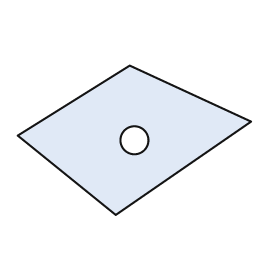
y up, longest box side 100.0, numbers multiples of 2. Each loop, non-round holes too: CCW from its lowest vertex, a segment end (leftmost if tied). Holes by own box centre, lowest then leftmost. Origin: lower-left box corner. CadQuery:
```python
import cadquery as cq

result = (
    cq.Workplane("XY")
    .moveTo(42.0, 0.0)
    .lineTo(100.0, 40.0)
    .lineTo(48.0, 64.0)
    .lineTo(0.0, 34.0)
    .close()
    .moveTo(50.0, 32.0)
    .circle(6.0)
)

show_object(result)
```